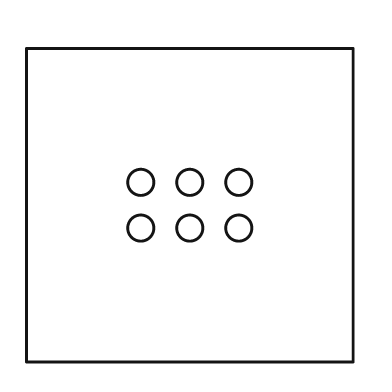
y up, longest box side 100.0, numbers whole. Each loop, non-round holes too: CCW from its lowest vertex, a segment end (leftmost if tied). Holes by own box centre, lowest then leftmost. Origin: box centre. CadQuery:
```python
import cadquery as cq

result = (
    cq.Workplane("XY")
    .moveTo(-50.0, -48.0)
    .lineTo(50.0, -48.0)
    .lineTo(50.0, 48.0)
    .lineTo(-50.0, 48.0)
    .close()
    .moveTo(-15.0, -7.0)
    .circle(4.0)
    .moveTo(0.0, -7.0)
    .circle(4.0)
    .moveTo(15.0, -7.0)
    .circle(4.0)
    .moveTo(-15.0, 7.0)
    .circle(4.0)
    .moveTo(0.0, 7.0)
    .circle(4.0)
    .moveTo(15.0, 7.0)
    .circle(4.0)
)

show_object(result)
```